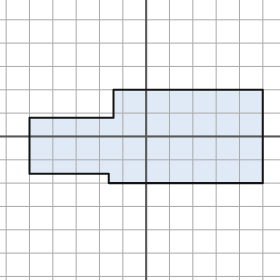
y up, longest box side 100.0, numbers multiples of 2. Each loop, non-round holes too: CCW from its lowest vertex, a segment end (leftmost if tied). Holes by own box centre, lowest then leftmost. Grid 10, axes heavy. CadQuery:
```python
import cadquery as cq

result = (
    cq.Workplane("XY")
    .moveTo(-16.0, -20.0)
    .lineTo(50.0, -20.0)
    .lineTo(50.0, 20.0)
    .lineTo(-14.0, 20.0)
    .lineTo(-14.0, 8.0)
    .lineTo(-50.0, 8.0)
    .lineTo(-50.0, -16.0)
    .lineTo(-16.0, -16.0)
    .close()
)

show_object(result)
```